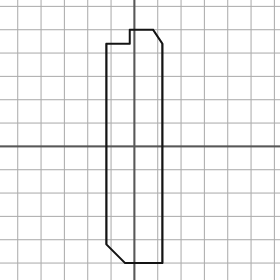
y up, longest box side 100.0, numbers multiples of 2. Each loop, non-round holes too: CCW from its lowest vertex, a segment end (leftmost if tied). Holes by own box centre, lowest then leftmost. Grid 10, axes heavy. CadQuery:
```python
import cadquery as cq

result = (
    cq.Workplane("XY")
    .moveTo(-4.0, -50.0)
    .lineTo(12.0, -50.0)
    .lineTo(12.0, 44.0)
    .lineTo(8.0, 50.0)
    .lineTo(-2.0, 50.0)
    .lineTo(-2.0, 44.0)
    .lineTo(-12.0, 44.0)
    .lineTo(-12.0, -42.0)
    .close()
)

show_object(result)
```